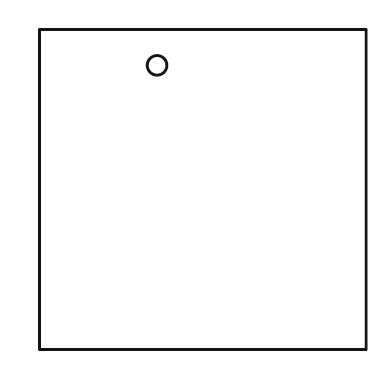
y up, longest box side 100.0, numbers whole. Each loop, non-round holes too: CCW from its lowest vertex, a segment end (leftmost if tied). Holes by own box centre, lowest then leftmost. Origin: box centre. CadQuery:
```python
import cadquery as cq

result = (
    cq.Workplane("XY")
    .moveTo(-50.0, -49.0)
    .lineTo(50.0, -49.0)
    .lineTo(50.0, 49.0)
    .lineTo(-50.0, 49.0)
    .close()
    .moveTo(-14.0, 38.0)
    .circle(3.0)
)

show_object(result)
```